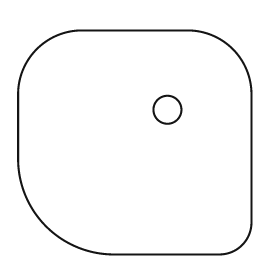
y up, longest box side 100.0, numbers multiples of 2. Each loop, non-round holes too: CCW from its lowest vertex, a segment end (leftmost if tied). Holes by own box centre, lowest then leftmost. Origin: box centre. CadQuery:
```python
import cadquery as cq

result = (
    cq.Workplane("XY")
    .moveTo(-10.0, -48.0)
    .lineTo(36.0, -48.0)
    .threePointArc((46.0, -44.0), (50.0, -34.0))
    .lineTo(50.0, 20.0)
    .threePointArc((42.0, 40.0), (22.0, 48.0))
    .lineTo(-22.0, 48.0)
    .threePointArc((-42.0, 40.0), (-50.0, 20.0))
    .lineTo(-50.0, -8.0)
    .threePointArc((-38.0, -36.0), (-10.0, -48.0))
    .close()
    .moveTo(14.0, 14.0)
    .circle(6.0)
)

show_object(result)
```